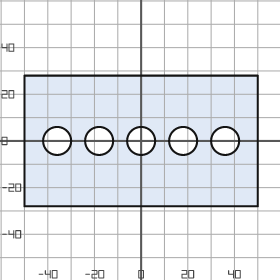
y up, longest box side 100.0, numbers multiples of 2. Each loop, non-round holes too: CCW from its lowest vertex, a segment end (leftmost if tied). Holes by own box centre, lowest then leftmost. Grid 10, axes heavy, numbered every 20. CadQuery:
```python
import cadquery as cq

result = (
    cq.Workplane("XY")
    .moveTo(-50.0, -28.0)
    .lineTo(50.0, -28.0)
    .lineTo(50.0, 28.0)
    .lineTo(-50.0, 28.0)
    .close()
    .moveTo(-36.0, 0.0)
    .circle(6.0)
    .moveTo(-18.0, 0.0)
    .circle(6.0)
    .moveTo(0.0, 0.0)
    .circle(6.0)
    .moveTo(18.0, 0.0)
    .circle(6.0)
    .moveTo(36.0, 0.0)
    .circle(6.0)
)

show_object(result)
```